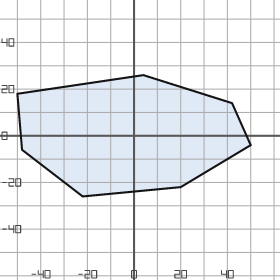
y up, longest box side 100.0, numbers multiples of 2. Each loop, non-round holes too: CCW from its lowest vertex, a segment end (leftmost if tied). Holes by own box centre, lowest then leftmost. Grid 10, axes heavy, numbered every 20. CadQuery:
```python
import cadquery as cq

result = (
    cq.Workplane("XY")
    .moveTo(-22.0, -26.0)
    .lineTo(20.0, -22.0)
    .lineTo(50.0, -4.0)
    .lineTo(42.0, 14.0)
    .lineTo(4.0, 26.0)
    .lineTo(-50.0, 18.0)
    .lineTo(-48.0, -6.0)
    .close()
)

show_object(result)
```